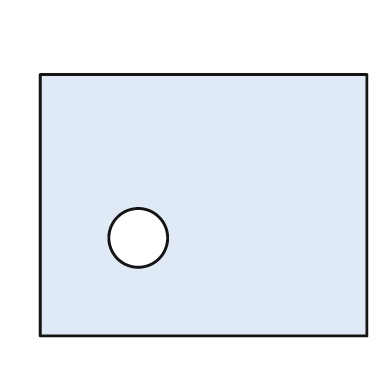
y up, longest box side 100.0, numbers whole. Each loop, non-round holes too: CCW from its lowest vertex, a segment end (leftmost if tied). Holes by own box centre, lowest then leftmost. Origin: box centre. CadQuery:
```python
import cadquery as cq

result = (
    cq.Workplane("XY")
    .moveTo(-50.0, -40.0)
    .lineTo(50.0, -40.0)
    .lineTo(50.0, 40.0)
    .lineTo(-50.0, 40.0)
    .close()
    .moveTo(-20.0, -10.0)
    .circle(9.0)
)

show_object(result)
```